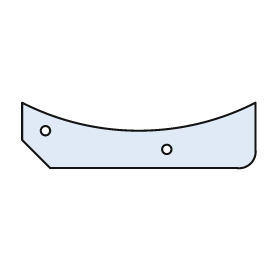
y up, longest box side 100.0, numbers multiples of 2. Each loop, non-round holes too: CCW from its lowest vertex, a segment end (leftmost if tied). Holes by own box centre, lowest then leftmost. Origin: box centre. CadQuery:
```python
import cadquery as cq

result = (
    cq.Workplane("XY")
    .moveTo(-38.0, -14.0)
    .lineTo(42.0, -14.0)
    .threePointArc((48.0, -12.0), (50.0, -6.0))
    .lineTo(50.0, 14.0)
    .threePointArc((0.0, 2.0), (-50.0, 14.0))
    .lineTo(-50.0, -2.0)
    .close()
    .moveTo(12.0, -6.0)
    .circle(2.0)
    .moveTo(-40.0, 2.0)
    .circle(2.0)
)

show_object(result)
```